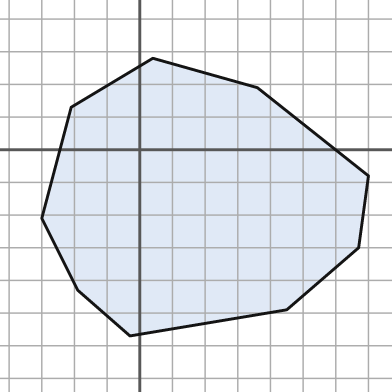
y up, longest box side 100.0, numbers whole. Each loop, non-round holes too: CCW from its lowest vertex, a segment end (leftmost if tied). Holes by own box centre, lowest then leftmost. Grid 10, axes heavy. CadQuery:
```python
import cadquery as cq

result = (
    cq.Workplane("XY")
    .moveTo(-3.0, -57.0)
    .lineTo(45.0, -49.0)
    .lineTo(67.0, -30.0)
    .lineTo(70.0, -8.0)
    .lineTo(36.0, 19.0)
    .lineTo(4.0, 28.0)
    .lineTo(-21.0, 13.0)
    .lineTo(-30.0, -21.0)
    .lineTo(-19.0, -43.0)
    .close()
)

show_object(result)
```